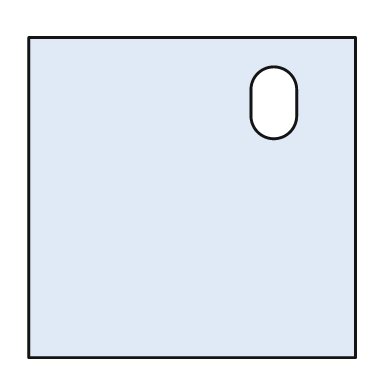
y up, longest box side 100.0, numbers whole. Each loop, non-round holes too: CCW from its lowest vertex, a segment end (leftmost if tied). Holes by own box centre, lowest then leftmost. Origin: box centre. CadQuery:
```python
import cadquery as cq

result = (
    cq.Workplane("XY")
    .moveTo(-50.0, -49.0)
    .lineTo(50.0, -49.0)
    .lineTo(50.0, 49.0)
    .lineTo(-50.0, 49.0)
    .close()
    .moveTo(18.0, 25.0)
    .threePointArc((25.0, 18.0), (32.0, 25.0))
    .lineTo(32.0, 33.0)
    .threePointArc((25.0, 40.0), (18.0, 33.0))
    .close()
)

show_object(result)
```